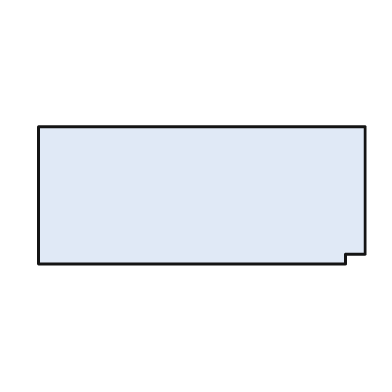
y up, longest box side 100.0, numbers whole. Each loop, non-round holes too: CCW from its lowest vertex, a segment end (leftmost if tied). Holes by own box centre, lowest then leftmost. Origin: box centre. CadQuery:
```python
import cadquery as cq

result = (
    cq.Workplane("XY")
    .moveTo(-50.0, -21.0)
    .lineTo(44.0, -21.0)
    .lineTo(44.0, -18.0)
    .lineTo(50.0, -18.0)
    .lineTo(50.0, 21.0)
    .lineTo(-50.0, 21.0)
    .close()
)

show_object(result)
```